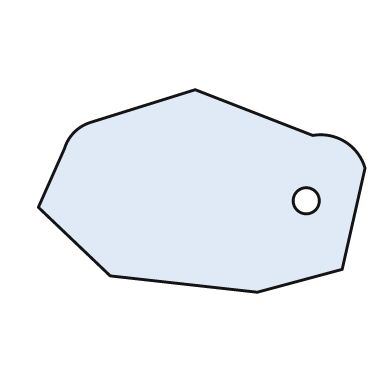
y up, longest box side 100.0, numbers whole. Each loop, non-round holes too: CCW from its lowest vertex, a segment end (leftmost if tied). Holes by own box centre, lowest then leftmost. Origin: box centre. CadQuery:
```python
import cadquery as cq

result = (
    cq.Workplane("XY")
    .moveTo(17.0, -31.0)
    .lineTo(43.0, -24.0)
    .lineTo(50.0, 7.0)
    .threePointArc((44.0, 15.0), (34.0, 17.0))
    .lineTo(-2.0, 31.0)
    .lineTo(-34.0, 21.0)
    .threePointArc((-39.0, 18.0), (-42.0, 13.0))
    .lineTo(-50.0, -5.0)
    .lineTo(-28.0, -26.0)
    .close()
    .moveTo(32.0, -3.0)
    .circle(4.0)
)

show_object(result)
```